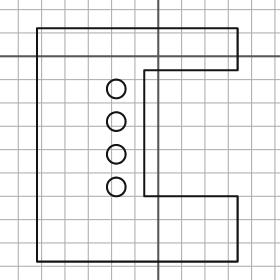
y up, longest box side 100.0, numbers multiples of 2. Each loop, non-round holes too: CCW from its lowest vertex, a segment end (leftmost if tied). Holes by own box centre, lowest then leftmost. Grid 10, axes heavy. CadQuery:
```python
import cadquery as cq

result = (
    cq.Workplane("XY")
    .moveTo(-52.0, -88.0)
    .lineTo(34.0, -88.0)
    .lineTo(34.0, -60.0)
    .lineTo(-6.0, -60.0)
    .lineTo(-6.0, -6.0)
    .lineTo(34.0, -6.0)
    .lineTo(34.0, 12.0)
    .lineTo(-52.0, 12.0)
    .close()
    .moveTo(-18.0, -56.0)
    .circle(4.0)
    .moveTo(-18.0, -42.0)
    .circle(4.0)
    .moveTo(-18.0, -28.0)
    .circle(4.0)
    .moveTo(-18.0, -14.0)
    .circle(4.0)
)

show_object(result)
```